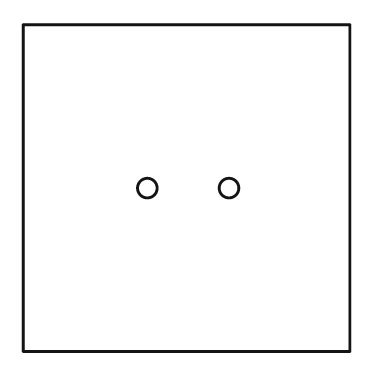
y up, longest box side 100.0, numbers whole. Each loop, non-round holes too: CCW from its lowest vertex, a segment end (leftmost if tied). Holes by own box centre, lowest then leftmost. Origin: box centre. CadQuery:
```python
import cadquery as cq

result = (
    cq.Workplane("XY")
    .moveTo(-50.0, -50.0)
    .lineTo(50.0, -50.0)
    .lineTo(50.0, 50.0)
    .lineTo(-50.0, 50.0)
    .close()
    .moveTo(-12.0, 0.0)
    .circle(3.0)
    .moveTo(13.0, 0.0)
    .circle(3.0)
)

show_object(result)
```